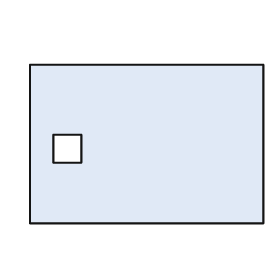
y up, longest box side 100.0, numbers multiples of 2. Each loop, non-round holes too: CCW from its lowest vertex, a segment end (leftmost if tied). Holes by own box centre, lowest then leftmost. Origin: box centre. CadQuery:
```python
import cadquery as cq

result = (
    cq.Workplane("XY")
    .moveTo(-50.0, -34.0)
    .lineTo(50.0, -34.0)
    .lineTo(50.0, 34.0)
    .lineTo(-50.0, 34.0)
    .close()
    .moveTo(-40.0, -8.0)
    .lineTo(-28.0, -8.0)
    .lineTo(-28.0, 4.0)
    .lineTo(-40.0, 4.0)
    .close()
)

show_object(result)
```